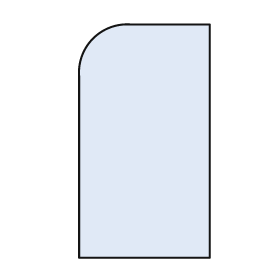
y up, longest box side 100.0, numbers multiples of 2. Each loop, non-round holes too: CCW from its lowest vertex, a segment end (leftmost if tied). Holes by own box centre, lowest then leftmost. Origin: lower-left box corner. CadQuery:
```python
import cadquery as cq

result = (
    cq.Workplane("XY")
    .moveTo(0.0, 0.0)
    .lineTo(56.0, 0.0)
    .lineTo(56.0, 100.0)
    .lineTo(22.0, 100.0)
    .threePointArc((6.0, 94.0), (0.0, 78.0))
    .close()
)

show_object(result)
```